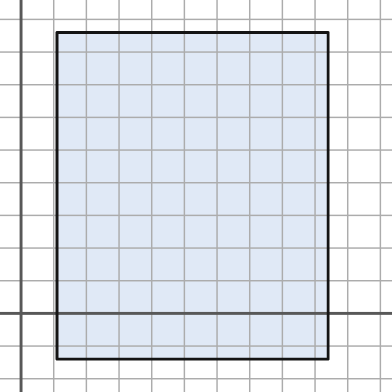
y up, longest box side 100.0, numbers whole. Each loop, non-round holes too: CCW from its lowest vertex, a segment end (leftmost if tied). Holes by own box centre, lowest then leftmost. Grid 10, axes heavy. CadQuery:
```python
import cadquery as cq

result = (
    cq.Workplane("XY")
    .moveTo(11.0, -14.0)
    .lineTo(94.0, -14.0)
    .lineTo(94.0, 86.0)
    .lineTo(11.0, 86.0)
    .close()
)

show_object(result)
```